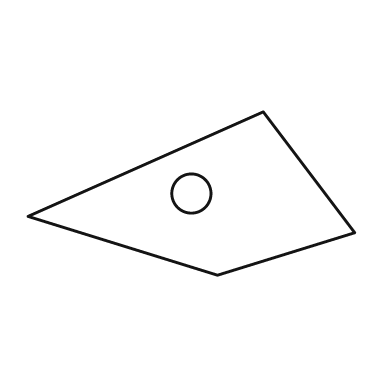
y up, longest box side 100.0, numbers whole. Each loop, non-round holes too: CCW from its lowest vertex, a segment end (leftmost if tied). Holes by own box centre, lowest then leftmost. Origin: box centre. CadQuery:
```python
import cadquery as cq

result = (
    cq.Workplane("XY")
    .moveTo(8.0, -25.0)
    .lineTo(50.0, -12.0)
    .lineTo(22.0, 25.0)
    .lineTo(-50.0, -7.0)
    .close()
    .moveTo(0.0, 0.0)
    .circle(6.0)
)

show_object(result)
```